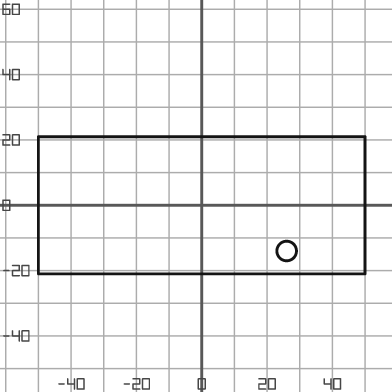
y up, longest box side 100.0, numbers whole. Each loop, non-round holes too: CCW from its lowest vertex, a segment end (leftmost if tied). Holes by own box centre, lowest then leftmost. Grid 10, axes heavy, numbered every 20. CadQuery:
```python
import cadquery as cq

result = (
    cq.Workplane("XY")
    .moveTo(-50.0, -21.0)
    .lineTo(50.0, -21.0)
    .lineTo(50.0, 21.0)
    .lineTo(-50.0, 21.0)
    .close()
    .moveTo(26.0, -14.0)
    .circle(3.0)
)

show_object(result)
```